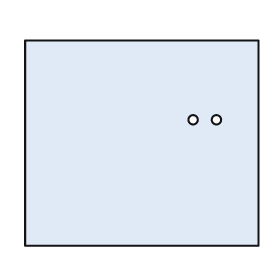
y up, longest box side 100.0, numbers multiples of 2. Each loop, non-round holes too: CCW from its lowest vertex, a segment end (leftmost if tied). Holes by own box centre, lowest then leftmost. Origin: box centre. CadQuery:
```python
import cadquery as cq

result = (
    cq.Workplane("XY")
    .moveTo(-50.0, -44.0)
    .lineTo(50.0, -44.0)
    .lineTo(50.0, 44.0)
    .lineTo(-50.0, 44.0)
    .close()
    .moveTo(22.0, 10.0)
    .circle(2.0)
    .moveTo(32.0, 10.0)
    .circle(2.0)
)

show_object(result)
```